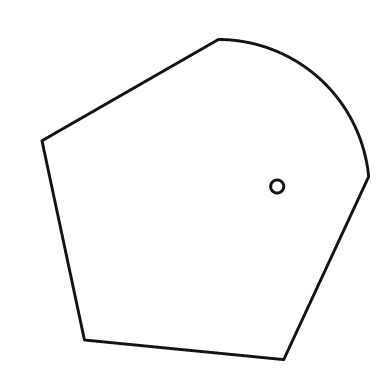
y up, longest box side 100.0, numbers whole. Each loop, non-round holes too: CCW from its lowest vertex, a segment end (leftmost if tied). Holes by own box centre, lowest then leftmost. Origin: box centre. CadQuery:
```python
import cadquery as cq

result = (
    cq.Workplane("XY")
    .moveTo(24.0, -49.0)
    .lineTo(50.0, 7.0)
    .threePointArc((35.0, 37.0), (4.0, 49.0))
    .lineTo(-50.0, 18.0)
    .lineTo(-37.0, -43.0)
    .close()
    .moveTo(22.0, 4.0)
    .circle(2.0)
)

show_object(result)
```